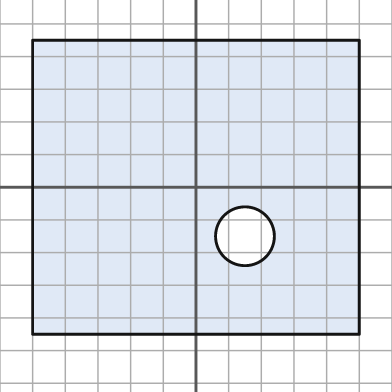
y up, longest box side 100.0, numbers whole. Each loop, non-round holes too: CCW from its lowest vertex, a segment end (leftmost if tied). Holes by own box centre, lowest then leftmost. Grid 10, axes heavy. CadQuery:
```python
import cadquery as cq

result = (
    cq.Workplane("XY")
    .moveTo(-50.0, -45.0)
    .lineTo(50.0, -45.0)
    .lineTo(50.0, 45.0)
    .lineTo(-50.0, 45.0)
    .close()
    .moveTo(15.0, -15.0)
    .circle(9.0)
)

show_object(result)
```